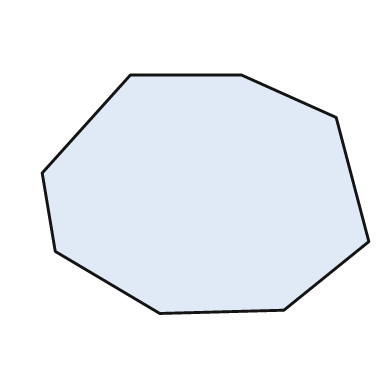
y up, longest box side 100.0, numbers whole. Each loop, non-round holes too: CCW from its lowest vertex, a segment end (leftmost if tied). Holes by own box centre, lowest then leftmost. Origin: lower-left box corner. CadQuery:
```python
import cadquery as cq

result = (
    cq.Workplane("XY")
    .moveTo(36.0, 0.0)
    .lineTo(74.0, 1.0)
    .lineTo(100.0, 22.0)
    .lineTo(90.0, 60.0)
    .lineTo(61.0, 73.0)
    .lineTo(27.0, 73.0)
    .lineTo(0.0, 43.0)
    .lineTo(4.0, 19.0)
    .close()
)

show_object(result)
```